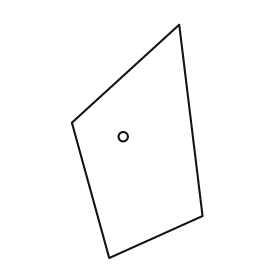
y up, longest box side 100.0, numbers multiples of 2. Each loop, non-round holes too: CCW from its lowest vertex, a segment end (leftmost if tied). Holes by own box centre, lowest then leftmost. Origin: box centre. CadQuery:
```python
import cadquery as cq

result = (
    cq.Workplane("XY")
    .moveTo(-12.0, -50.0)
    .lineTo(28.0, -32.0)
    .lineTo(18.0, 50.0)
    .lineTo(-28.0, 8.0)
    .close()
    .moveTo(-6.0, 2.0)
    .circle(2.0)
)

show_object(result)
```